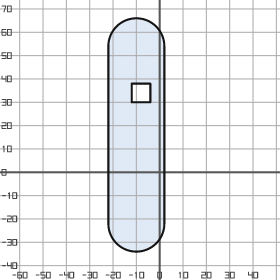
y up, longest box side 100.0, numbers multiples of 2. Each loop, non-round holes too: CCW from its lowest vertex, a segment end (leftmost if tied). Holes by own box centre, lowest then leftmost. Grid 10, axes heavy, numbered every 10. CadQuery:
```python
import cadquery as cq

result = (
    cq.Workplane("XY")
    .moveTo(-22.0, -22.0)
    .threePointArc((-10.0, -34.0), (2.0, -22.0))
    .lineTo(2.0, 54.0)
    .threePointArc((-10.0, 66.0), (-22.0, 54.0))
    .close()
    .moveTo(-12.0, 30.0)
    .lineTo(-4.0, 30.0)
    .lineTo(-4.0, 38.0)
    .lineTo(-12.0, 38.0)
    .close()
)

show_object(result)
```